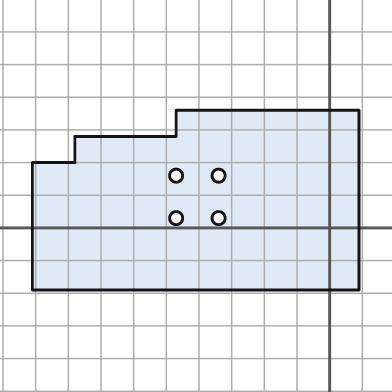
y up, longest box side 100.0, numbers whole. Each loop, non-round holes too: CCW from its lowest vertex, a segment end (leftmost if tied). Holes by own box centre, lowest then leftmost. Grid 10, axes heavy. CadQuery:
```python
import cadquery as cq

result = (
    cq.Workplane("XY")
    .moveTo(-91.0, -19.0)
    .lineTo(9.0, -19.0)
    .lineTo(9.0, 36.0)
    .lineTo(-47.0, 36.0)
    .lineTo(-47.0, 28.0)
    .lineTo(-78.0, 28.0)
    .lineTo(-78.0, 20.0)
    .lineTo(-91.0, 20.0)
    .close()
    .moveTo(-47.0, 3.0)
    .circle(2.0)
    .moveTo(-34.0, 3.0)
    .circle(2.0)
    .moveTo(-47.0, 16.0)
    .circle(2.0)
    .moveTo(-34.0, 16.0)
    .circle(2.0)
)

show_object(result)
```